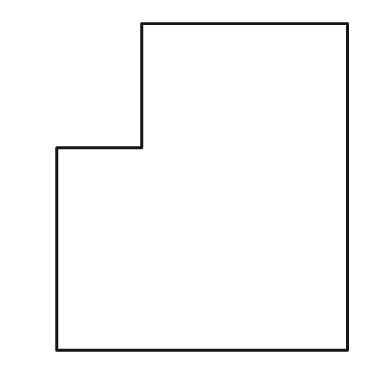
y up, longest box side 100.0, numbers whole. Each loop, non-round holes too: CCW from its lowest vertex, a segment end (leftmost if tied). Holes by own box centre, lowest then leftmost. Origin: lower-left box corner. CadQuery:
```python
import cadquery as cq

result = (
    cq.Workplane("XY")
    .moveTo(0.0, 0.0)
    .lineTo(89.0, 0.0)
    .lineTo(89.0, 100.0)
    .lineTo(26.0, 100.0)
    .lineTo(26.0, 62.0)
    .lineTo(0.0, 62.0)
    .close()
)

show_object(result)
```